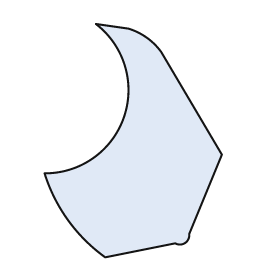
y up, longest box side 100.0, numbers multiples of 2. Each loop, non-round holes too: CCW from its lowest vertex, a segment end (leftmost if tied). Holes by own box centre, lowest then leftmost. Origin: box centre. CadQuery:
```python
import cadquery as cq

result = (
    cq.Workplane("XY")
    .moveTo(-12.0, -50.0)
    .lineTo(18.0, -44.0)
    .threePointArc((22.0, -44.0), (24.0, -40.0))
    .lineTo(38.0, -6.0)
    .lineTo(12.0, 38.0)
    .threePointArc((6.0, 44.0), (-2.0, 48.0))
    .lineTo(-16.0, 50.0)
    .threePointArc((-4.0, 10.0), (-38.0, -14.0))
    .threePointArc((-28.0, -34.0), (-12.0, -50.0))
    .close()
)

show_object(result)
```